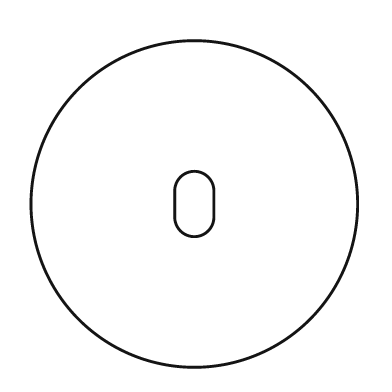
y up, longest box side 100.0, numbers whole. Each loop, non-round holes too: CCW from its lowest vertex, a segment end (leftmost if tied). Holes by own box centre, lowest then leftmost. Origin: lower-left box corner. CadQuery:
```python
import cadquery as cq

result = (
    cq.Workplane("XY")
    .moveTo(50.0, 50.0)
    .circle(50.0)
    .moveTo(44.0, 46.0)
    .threePointArc((50.0, 40.0), (56.0, 46.0))
    .lineTo(56.0, 54.0)
    .threePointArc((50.0, 60.0), (44.0, 54.0))
    .close()
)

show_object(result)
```